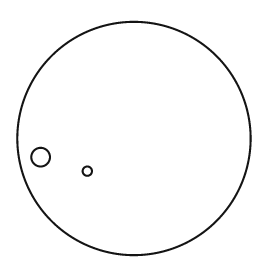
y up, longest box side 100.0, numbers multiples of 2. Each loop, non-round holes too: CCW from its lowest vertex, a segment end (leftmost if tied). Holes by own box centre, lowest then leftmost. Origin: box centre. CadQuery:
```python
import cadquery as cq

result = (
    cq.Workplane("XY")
    .moveTo(0.0, 0.0)
    .circle(50.0)
    .moveTo(-20.0, -14.0)
    .circle(2.0)
    .moveTo(-40.0, -8.0)
    .circle(4.0)
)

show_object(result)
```